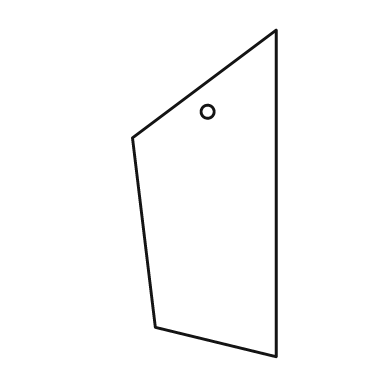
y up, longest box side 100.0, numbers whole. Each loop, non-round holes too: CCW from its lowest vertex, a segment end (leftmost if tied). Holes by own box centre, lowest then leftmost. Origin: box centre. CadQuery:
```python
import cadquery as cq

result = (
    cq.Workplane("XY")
    .moveTo(22.0, -50.0)
    .lineTo(22.0, 50.0)
    .lineTo(-22.0, 17.0)
    .lineTo(-15.0, -41.0)
    .close()
    .moveTo(1.0, 25.0)
    .circle(2.0)
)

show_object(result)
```